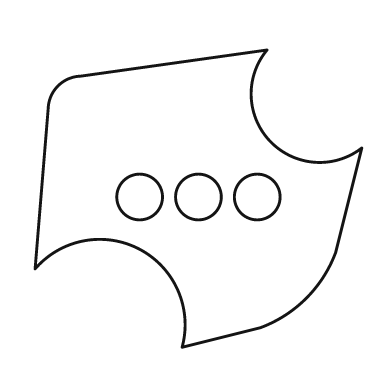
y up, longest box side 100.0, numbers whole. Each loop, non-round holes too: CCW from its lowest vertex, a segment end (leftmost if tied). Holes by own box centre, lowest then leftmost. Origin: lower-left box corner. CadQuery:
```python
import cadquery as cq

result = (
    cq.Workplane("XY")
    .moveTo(45.0, 0.0)
    .lineTo(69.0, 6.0)
    .threePointArc((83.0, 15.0), (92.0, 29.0))
    .lineTo(100.0, 61.0)
    .threePointArc((72.0, 63.0), (71.0, 91.0))
    .lineTo(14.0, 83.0)
    .threePointArc((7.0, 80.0), (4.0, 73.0))
    .lineTo(0.0, 24.0)
    .threePointArc((32.0, 30.0), (45.0, 0.0))
    .close()
    .moveTo(32.0, 46.0)
    .circle(7.0)
    .moveTo(50.0, 46.0)
    .circle(7.0)
    .moveTo(68.0, 46.0)
    .circle(7.0)
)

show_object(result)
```